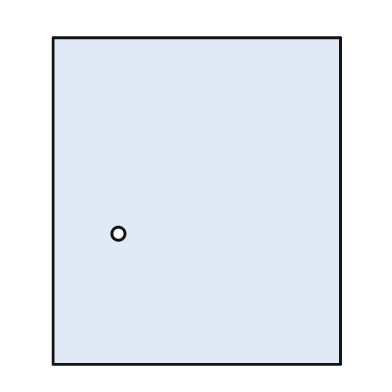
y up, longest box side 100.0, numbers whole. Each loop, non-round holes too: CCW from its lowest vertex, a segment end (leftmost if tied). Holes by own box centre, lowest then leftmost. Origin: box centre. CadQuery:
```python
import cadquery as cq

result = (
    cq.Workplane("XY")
    .moveTo(-44.0, -50.0)
    .lineTo(44.0, -50.0)
    .lineTo(44.0, 50.0)
    .lineTo(-44.0, 50.0)
    .close()
    .moveTo(-24.0, -10.0)
    .circle(2.0)
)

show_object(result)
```